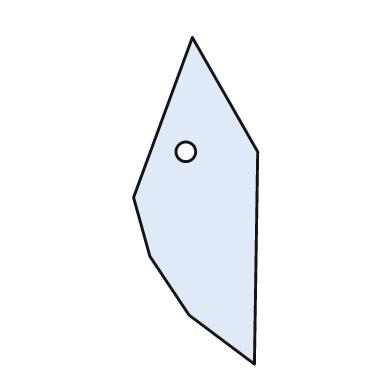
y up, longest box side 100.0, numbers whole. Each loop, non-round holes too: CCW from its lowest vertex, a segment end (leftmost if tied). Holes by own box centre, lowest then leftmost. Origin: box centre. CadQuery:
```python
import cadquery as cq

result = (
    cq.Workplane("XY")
    .moveTo(18.0, -50.0)
    .lineTo(19.0, 15.0)
    .lineTo(-1.0, 50.0)
    .lineTo(-19.0, 1.0)
    .lineTo(-14.0, -17.0)
    .lineTo(-2.0, -35.0)
    .close()
    .moveTo(-3.0, 15.0)
    .circle(3.0)
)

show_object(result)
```